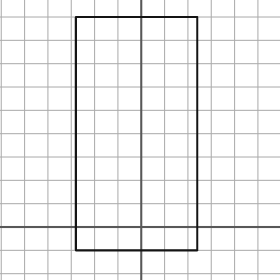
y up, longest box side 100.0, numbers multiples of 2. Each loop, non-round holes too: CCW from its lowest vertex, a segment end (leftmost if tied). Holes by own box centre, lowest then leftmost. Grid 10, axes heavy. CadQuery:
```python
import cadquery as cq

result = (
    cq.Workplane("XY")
    .moveTo(-28.0, -10.0)
    .lineTo(24.0, -10.0)
    .lineTo(24.0, 90.0)
    .lineTo(-28.0, 90.0)
    .close()
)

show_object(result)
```